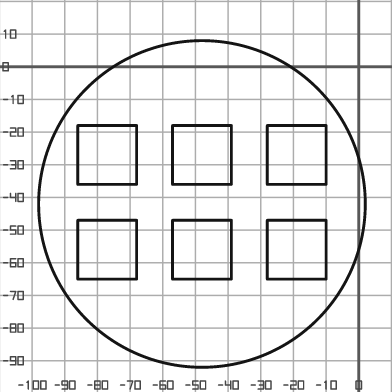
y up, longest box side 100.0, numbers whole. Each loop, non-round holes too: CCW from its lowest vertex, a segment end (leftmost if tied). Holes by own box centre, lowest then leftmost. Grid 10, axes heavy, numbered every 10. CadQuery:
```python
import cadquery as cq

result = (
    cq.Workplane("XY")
    .moveTo(-48.0, -42.0)
    .circle(50.0)
    .moveTo(-86.0, -65.0)
    .lineTo(-68.0, -65.0)
    .lineTo(-68.0, -47.0)
    .lineTo(-86.0, -47.0)
    .close()
    .moveTo(-57.0, -65.0)
    .lineTo(-39.0, -65.0)
    .lineTo(-39.0, -47.0)
    .lineTo(-57.0, -47.0)
    .close()
    .moveTo(-28.0, -65.0)
    .lineTo(-10.0, -65.0)
    .lineTo(-10.0, -47.0)
    .lineTo(-28.0, -47.0)
    .close()
    .moveTo(-86.0, -36.0)
    .lineTo(-68.0, -36.0)
    .lineTo(-68.0, -18.0)
    .lineTo(-86.0, -18.0)
    .close()
    .moveTo(-57.0, -36.0)
    .lineTo(-39.0, -36.0)
    .lineTo(-39.0, -18.0)
    .lineTo(-57.0, -18.0)
    .close()
    .moveTo(-28.0, -36.0)
    .lineTo(-10.0, -36.0)
    .lineTo(-10.0, -18.0)
    .lineTo(-28.0, -18.0)
    .close()
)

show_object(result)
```